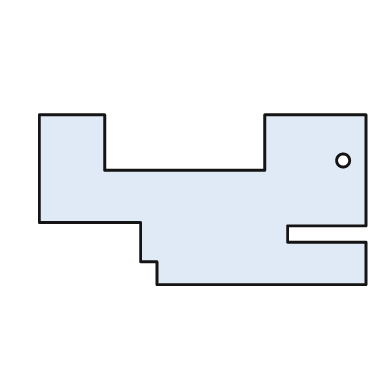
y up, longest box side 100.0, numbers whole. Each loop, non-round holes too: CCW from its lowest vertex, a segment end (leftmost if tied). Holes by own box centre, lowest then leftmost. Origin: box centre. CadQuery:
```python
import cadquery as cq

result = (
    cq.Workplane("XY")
    .moveTo(-14.0, -26.0)
    .lineTo(50.0, -26.0)
    .lineTo(50.0, -13.0)
    .lineTo(26.0, -13.0)
    .lineTo(26.0, -8.0)
    .lineTo(50.0, -8.0)
    .lineTo(50.0, 26.0)
    .lineTo(19.0, 26.0)
    .lineTo(19.0, 9.0)
    .lineTo(-30.0, 9.0)
    .lineTo(-30.0, 26.0)
    .lineTo(-50.0, 26.0)
    .lineTo(-50.0, -7.0)
    .lineTo(-19.0, -7.0)
    .lineTo(-19.0, -19.0)
    .lineTo(-14.0, -19.0)
    .close()
    .moveTo(43.0, 12.0)
    .circle(2.0)
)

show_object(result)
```